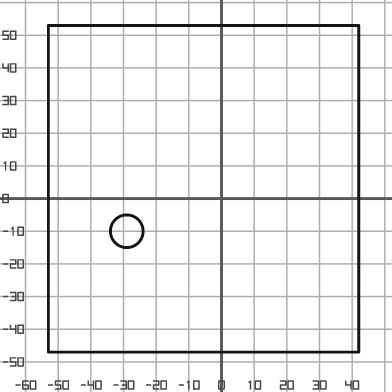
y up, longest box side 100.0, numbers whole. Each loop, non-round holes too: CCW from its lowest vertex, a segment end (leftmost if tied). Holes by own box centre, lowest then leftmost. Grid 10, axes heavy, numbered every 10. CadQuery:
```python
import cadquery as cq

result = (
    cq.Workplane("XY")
    .moveTo(-53.0, -47.0)
    .lineTo(42.0, -47.0)
    .lineTo(42.0, 53.0)
    .lineTo(-53.0, 53.0)
    .close()
    .moveTo(-29.0, -10.0)
    .circle(5.0)
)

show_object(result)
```